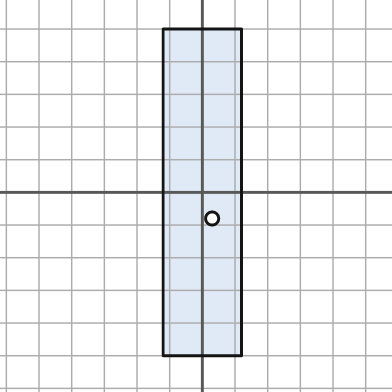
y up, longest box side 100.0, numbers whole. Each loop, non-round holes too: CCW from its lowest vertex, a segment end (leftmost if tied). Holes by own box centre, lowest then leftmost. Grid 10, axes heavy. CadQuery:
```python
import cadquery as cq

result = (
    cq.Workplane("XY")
    .moveTo(-12.0, -50.0)
    .lineTo(12.0, -50.0)
    .lineTo(12.0, 50.0)
    .lineTo(-12.0, 50.0)
    .close()
    .moveTo(3.0, -8.0)
    .circle(2.0)
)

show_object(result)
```